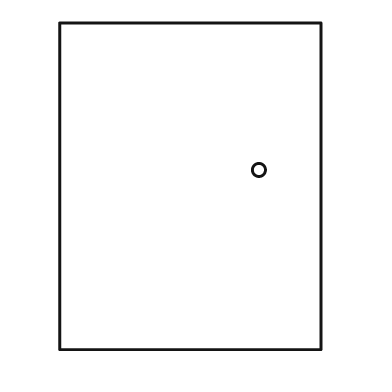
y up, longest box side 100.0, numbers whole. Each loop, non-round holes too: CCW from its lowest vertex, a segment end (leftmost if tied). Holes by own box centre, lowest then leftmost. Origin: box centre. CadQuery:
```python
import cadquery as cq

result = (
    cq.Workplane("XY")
    .moveTo(-40.0, -50.0)
    .lineTo(40.0, -50.0)
    .lineTo(40.0, 50.0)
    .lineTo(-40.0, 50.0)
    .close()
    .moveTo(21.0, 5.0)
    .circle(2.0)
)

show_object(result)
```